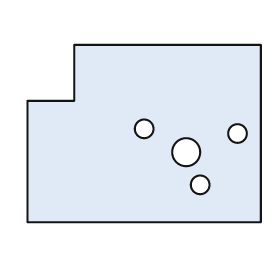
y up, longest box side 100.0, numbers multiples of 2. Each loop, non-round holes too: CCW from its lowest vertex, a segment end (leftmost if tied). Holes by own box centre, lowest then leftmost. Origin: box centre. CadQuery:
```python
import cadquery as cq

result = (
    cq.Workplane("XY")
    .moveTo(-50.0, -38.0)
    .lineTo(50.0, -38.0)
    .lineTo(50.0, 38.0)
    .lineTo(-30.0, 38.0)
    .lineTo(-30.0, 14.0)
    .lineTo(-50.0, 14.0)
    .close()
    .moveTo(24.0, -22.0)
    .circle(4.0)
    .moveTo(18.0, -8.0)
    .circle(6.0)
    .moveTo(40.0, 0.0)
    .circle(4.0)
    .moveTo(0.0, 2.0)
    .circle(4.0)
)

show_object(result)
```